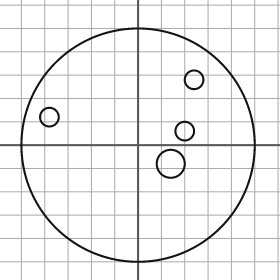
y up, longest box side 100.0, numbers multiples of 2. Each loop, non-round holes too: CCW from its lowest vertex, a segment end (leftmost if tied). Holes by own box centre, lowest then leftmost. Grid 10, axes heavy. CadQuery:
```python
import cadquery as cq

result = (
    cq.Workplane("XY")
    .moveTo(0.0, 0.0)
    .circle(50.0)
    .moveTo(14.0, -8.0)
    .circle(6.0)
    .moveTo(20.0, 6.0)
    .circle(4.0)
    .moveTo(-38.0, 12.0)
    .circle(4.0)
    .moveTo(24.0, 28.0)
    .circle(4.0)
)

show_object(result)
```